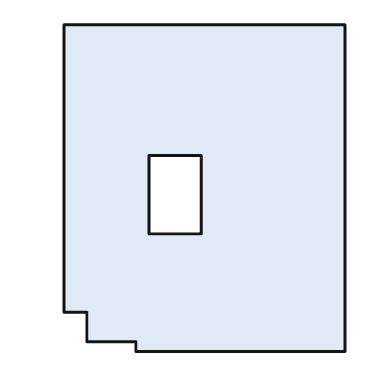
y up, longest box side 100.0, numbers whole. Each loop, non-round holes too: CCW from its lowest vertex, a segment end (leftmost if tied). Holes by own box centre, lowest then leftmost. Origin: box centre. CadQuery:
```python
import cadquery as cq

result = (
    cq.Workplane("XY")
    .moveTo(-21.0, -50.0)
    .lineTo(43.0, -50.0)
    .lineTo(43.0, 50.0)
    .lineTo(-43.0, 50.0)
    .lineTo(-43.0, -38.0)
    .lineTo(-36.0, -38.0)
    .lineTo(-36.0, -47.0)
    .lineTo(-21.0, -47.0)
    .close()
    .moveTo(-17.0, -14.0)
    .lineTo(-1.0, -14.0)
    .lineTo(-1.0, 10.0)
    .lineTo(-17.0, 10.0)
    .close()
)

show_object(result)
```